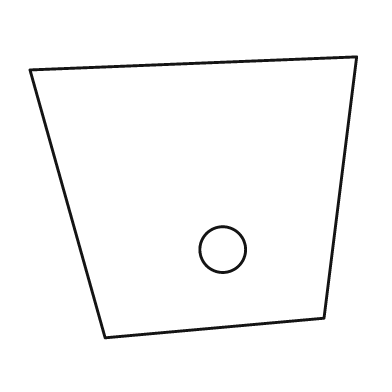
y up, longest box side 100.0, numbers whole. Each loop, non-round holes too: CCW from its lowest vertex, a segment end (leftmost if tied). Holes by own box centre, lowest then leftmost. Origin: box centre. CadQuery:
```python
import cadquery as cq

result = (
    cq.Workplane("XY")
    .moveTo(-27.0, -43.0)
    .lineTo(40.0, -37.0)
    .lineTo(50.0, 43.0)
    .lineTo(-50.0, 39.0)
    .close()
    .moveTo(9.0, -16.0)
    .circle(7.0)
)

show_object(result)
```